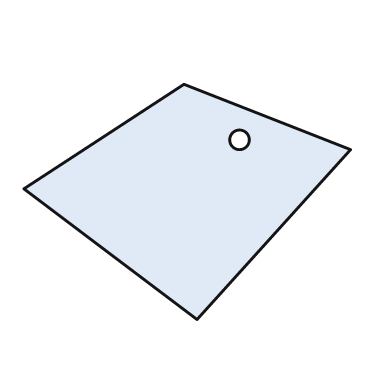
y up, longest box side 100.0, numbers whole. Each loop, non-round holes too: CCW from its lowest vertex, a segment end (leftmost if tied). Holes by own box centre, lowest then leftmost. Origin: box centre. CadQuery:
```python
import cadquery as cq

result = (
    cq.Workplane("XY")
    .moveTo(3.0, -36.0)
    .lineTo(50.0, 16.0)
    .lineTo(-1.0, 36.0)
    .lineTo(-50.0, 4.0)
    .close()
    .moveTo(16.0, 19.0)
    .circle(3.0)
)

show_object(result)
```